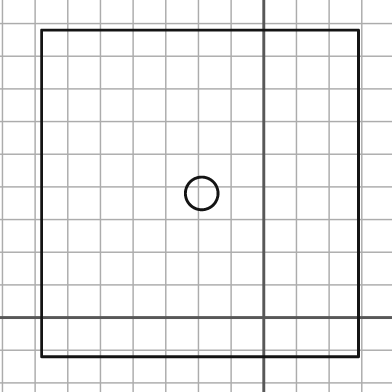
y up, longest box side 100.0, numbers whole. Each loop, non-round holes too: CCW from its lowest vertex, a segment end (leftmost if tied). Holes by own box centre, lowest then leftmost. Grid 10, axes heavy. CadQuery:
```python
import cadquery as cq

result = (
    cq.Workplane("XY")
    .moveTo(-68.0, -12.0)
    .lineTo(29.0, -12.0)
    .lineTo(29.0, 88.0)
    .lineTo(-68.0, 88.0)
    .close()
    .moveTo(-19.0, 38.0)
    .circle(5.0)
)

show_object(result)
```